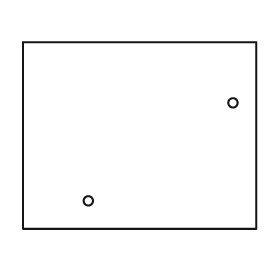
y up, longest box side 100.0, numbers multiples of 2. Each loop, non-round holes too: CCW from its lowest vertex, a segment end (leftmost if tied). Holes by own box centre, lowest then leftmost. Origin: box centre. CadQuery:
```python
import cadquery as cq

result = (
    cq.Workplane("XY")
    .moveTo(-50.0, -40.0)
    .lineTo(50.0, -40.0)
    .lineTo(50.0, 40.0)
    .lineTo(-50.0, 40.0)
    .close()
    .moveTo(-22.0, -28.0)
    .circle(2.0)
    .moveTo(40.0, 14.0)
    .circle(2.0)
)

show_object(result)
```